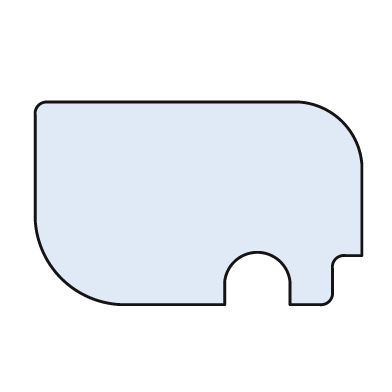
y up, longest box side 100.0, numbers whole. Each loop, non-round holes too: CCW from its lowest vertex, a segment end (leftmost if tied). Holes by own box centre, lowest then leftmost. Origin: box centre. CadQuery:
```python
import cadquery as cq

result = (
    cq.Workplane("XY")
    .moveTo(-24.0, -31.0)
    .lineTo(8.0, -31.0)
    .lineTo(8.0, -24.0)
    .threePointArc((18.0, -15.0), (28.0, -24.0))
    .lineTo(28.0, -31.0)
    .lineTo(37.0, -31.0)
    .threePointArc((40.0, -30.0), (41.0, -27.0))
    .lineTo(41.0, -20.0)
    .threePointArc((42.0, -17.0), (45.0, -16.0))
    .lineTo(50.0, -16.0)
    .lineTo(50.0, 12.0)
    .threePointArc((44.0, 25.0), (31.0, 31.0))
    .lineTo(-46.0, 31.0)
    .threePointArc((-49.0, 30.0), (-50.0, 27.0))
    .lineTo(-50.0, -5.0)
    .threePointArc((-42.0, -23.0), (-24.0, -31.0))
    .close()
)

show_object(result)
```